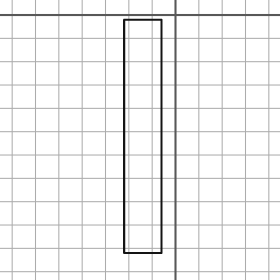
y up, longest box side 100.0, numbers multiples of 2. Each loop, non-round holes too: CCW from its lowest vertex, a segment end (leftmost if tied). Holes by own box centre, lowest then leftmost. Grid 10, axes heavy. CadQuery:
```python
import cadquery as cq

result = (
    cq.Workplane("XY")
    .moveTo(-22.0, -102.0)
    .lineTo(-6.0, -102.0)
    .lineTo(-6.0, -2.0)
    .lineTo(-22.0, -2.0)
    .close()
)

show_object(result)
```